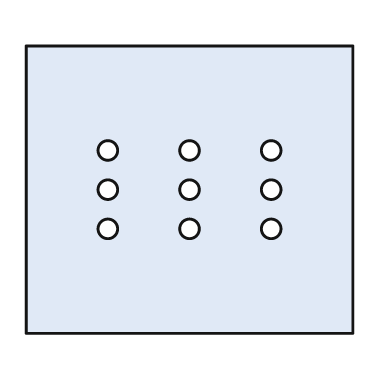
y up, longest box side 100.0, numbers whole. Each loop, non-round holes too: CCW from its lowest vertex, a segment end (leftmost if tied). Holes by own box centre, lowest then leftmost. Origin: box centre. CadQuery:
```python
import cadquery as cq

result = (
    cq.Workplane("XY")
    .moveTo(-50.0, -44.0)
    .lineTo(50.0, -44.0)
    .lineTo(50.0, 44.0)
    .lineTo(-50.0, 44.0)
    .close()
    .moveTo(-25.0, -12.0)
    .circle(3.0)
    .moveTo(0.0, -12.0)
    .circle(3.0)
    .moveTo(25.0, -12.0)
    .circle(3.0)
    .moveTo(-25.0, 0.0)
    .circle(3.0)
    .moveTo(0.0, 0.0)
    .circle(3.0)
    .moveTo(25.0, 0.0)
    .circle(3.0)
    .moveTo(-25.0, 12.0)
    .circle(3.0)
    .moveTo(0.0, 12.0)
    .circle(3.0)
    .moveTo(25.0, 12.0)
    .circle(3.0)
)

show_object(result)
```